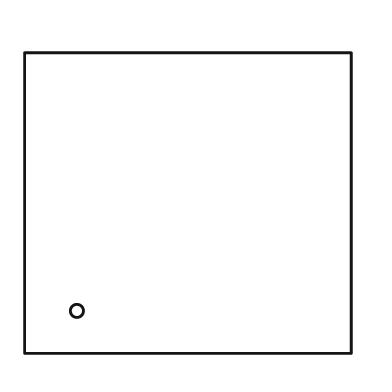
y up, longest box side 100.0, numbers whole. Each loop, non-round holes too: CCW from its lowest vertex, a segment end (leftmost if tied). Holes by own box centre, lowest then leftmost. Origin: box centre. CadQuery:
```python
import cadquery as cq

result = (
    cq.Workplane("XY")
    .moveTo(-50.0, -46.0)
    .lineTo(50.0, -46.0)
    .lineTo(50.0, 46.0)
    .lineTo(-50.0, 46.0)
    .close()
    .moveTo(-34.0, -33.0)
    .circle(2.0)
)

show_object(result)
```